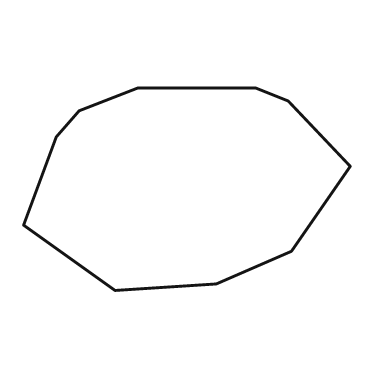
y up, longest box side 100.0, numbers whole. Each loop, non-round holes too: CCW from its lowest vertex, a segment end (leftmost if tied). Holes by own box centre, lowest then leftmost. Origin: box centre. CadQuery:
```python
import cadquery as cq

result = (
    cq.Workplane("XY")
    .moveTo(-22.0, -31.0)
    .lineTo(9.0, -29.0)
    .lineTo(32.0, -19.0)
    .lineTo(50.0, 7.0)
    .lineTo(31.0, 27.0)
    .lineTo(21.0, 31.0)
    .lineTo(-15.0, 31.0)
    .lineTo(-33.0, 24.0)
    .lineTo(-40.0, 16.0)
    .lineTo(-50.0, -11.0)
    .close()
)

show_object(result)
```